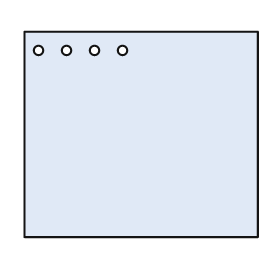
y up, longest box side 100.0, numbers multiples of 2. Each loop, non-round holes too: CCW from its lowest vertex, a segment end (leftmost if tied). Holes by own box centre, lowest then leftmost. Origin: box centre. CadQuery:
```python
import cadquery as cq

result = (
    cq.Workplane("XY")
    .moveTo(-50.0, -44.0)
    .lineTo(50.0, -44.0)
    .lineTo(50.0, 44.0)
    .lineTo(-50.0, 44.0)
    .close()
    .moveTo(-44.0, 36.0)
    .circle(2.0)
    .moveTo(-32.0, 36.0)
    .circle(2.0)
    .moveTo(-20.0, 36.0)
    .circle(2.0)
    .moveTo(-8.0, 36.0)
    .circle(2.0)
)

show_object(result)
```